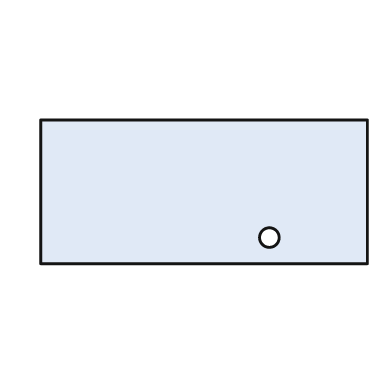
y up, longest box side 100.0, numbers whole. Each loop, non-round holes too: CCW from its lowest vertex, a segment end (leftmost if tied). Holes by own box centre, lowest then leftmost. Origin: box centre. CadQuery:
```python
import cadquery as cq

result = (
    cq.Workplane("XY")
    .moveTo(-50.0, -22.0)
    .lineTo(50.0, -22.0)
    .lineTo(50.0, 22.0)
    .lineTo(-50.0, 22.0)
    .close()
    .moveTo(20.0, -14.0)
    .circle(3.0)
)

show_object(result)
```